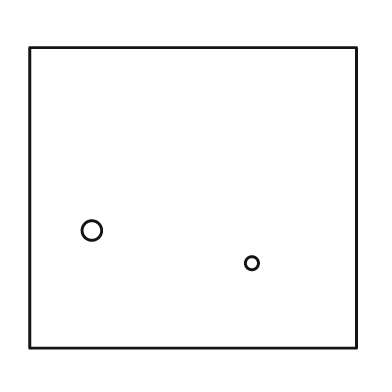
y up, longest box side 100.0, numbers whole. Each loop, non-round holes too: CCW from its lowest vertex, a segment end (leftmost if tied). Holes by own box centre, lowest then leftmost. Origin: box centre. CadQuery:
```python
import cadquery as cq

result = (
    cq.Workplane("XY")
    .moveTo(-50.0, -46.0)
    .lineTo(50.0, -46.0)
    .lineTo(50.0, 46.0)
    .lineTo(-50.0, 46.0)
    .close()
    .moveTo(18.0, -20.0)
    .circle(2.0)
    .moveTo(-31.0, -10.0)
    .circle(3.0)
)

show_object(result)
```